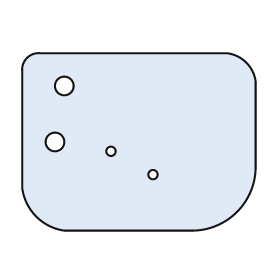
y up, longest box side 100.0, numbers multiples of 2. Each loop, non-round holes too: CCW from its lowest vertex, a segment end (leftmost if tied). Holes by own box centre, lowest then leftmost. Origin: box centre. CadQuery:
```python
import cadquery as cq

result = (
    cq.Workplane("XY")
    .moveTo(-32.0, -38.0)
    .lineTo(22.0, -38.0)
    .threePointArc((42.0, -30.0), (50.0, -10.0))
    .lineTo(50.0, 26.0)
    .threePointArc((46.0, 34.0), (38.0, 38.0))
    .lineTo(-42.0, 38.0)
    .threePointArc((-48.0, 36.0), (-50.0, 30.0))
    .lineTo(-50.0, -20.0)
    .threePointArc((-44.0, -32.0), (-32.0, -38.0))
    .close()
    .moveTo(6.0, -14.0)
    .circle(2.0)
    .moveTo(-12.0, -4.0)
    .circle(2.0)
    .moveTo(-36.0, 0.0)
    .circle(4.0)
    .moveTo(-32.0, 24.0)
    .circle(4.0)
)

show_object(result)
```